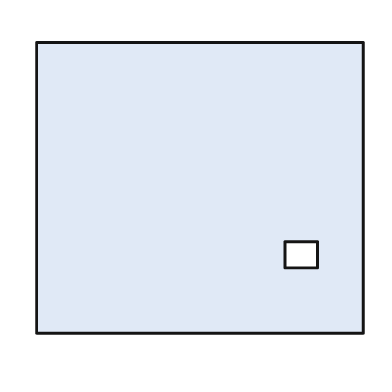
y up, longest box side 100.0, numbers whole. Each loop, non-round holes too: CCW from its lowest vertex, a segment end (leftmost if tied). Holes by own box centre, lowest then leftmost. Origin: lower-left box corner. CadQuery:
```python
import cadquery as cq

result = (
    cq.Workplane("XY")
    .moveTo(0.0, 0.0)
    .lineTo(100.0, 0.0)
    .lineTo(100.0, 89.0)
    .lineTo(0.0, 89.0)
    .close()
    .moveTo(76.0, 20.0)
    .lineTo(86.0, 20.0)
    .lineTo(86.0, 28.0)
    .lineTo(76.0, 28.0)
    .close()
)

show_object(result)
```